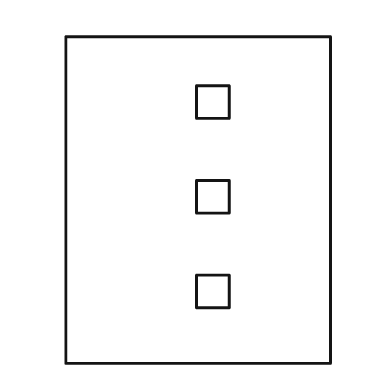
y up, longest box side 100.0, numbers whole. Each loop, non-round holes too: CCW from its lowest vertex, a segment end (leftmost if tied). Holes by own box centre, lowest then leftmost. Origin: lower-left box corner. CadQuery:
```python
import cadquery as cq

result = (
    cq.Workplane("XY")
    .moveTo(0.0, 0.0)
    .lineTo(81.0, 0.0)
    .lineTo(81.0, 100.0)
    .lineTo(0.0, 100.0)
    .close()
    .moveTo(40.0, 17.0)
    .lineTo(50.0, 17.0)
    .lineTo(50.0, 27.0)
    .lineTo(40.0, 27.0)
    .close()
    .moveTo(40.0, 46.0)
    .lineTo(50.0, 46.0)
    .lineTo(50.0, 56.0)
    .lineTo(40.0, 56.0)
    .close()
    .moveTo(40.0, 75.0)
    .lineTo(50.0, 75.0)
    .lineTo(50.0, 85.0)
    .lineTo(40.0, 85.0)
    .close()
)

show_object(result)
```